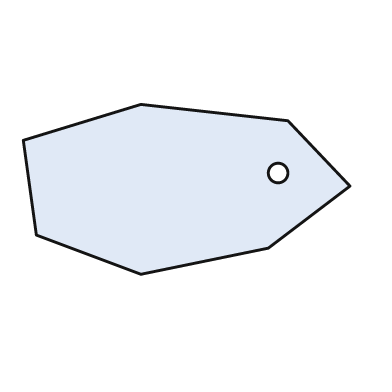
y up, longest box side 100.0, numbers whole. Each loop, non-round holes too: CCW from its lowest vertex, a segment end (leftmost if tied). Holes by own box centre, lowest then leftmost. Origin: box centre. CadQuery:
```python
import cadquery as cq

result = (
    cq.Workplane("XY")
    .moveTo(-14.0, -26.0)
    .lineTo(25.0, -18.0)
    .lineTo(50.0, 1.0)
    .lineTo(31.0, 21.0)
    .lineTo(-14.0, 26.0)
    .lineTo(-50.0, 15.0)
    .lineTo(-46.0, -14.0)
    .close()
    .moveTo(28.0, 5.0)
    .circle(3.0)
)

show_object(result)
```